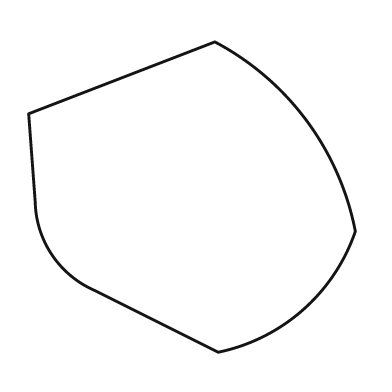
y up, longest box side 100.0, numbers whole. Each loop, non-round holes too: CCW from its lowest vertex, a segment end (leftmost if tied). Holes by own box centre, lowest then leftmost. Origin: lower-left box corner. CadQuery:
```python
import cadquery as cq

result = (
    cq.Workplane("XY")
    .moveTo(58.0, 0.0)
    .threePointArc((84.0, 13.0), (100.0, 37.0))
    .threePointArc((85.0, 71.0), (57.0, 95.0))
    .lineTo(0.0, 73.0)
    .lineTo(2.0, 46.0)
    .threePointArc((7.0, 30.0), (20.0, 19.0))
    .close()
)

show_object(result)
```